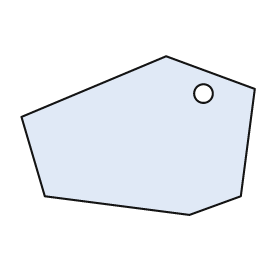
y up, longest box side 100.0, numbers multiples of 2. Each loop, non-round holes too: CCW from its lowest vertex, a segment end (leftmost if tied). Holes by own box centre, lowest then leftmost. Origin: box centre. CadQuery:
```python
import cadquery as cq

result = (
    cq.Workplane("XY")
    .moveTo(22.0, -34.0)
    .lineTo(44.0, -26.0)
    .lineTo(50.0, 20.0)
    .lineTo(12.0, 34.0)
    .lineTo(-50.0, 8.0)
    .lineTo(-40.0, -26.0)
    .close()
    .moveTo(28.0, 18.0)
    .circle(4.0)
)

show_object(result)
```